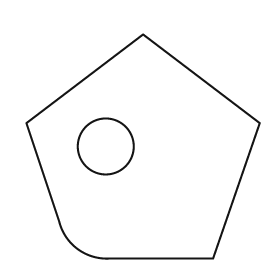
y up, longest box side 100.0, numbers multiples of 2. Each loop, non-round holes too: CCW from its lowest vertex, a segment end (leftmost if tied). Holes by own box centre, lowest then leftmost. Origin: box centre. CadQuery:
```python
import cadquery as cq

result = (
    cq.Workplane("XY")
    .moveTo(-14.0, -48.0)
    .lineTo(30.0, -48.0)
    .lineTo(50.0, 10.0)
    .lineTo(0.0, 48.0)
    .lineTo(-50.0, 10.0)
    .lineTo(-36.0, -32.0)
    .threePointArc((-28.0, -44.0), (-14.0, -48.0))
    .close()
    .moveTo(-16.0, 0.0)
    .circle(12.0)
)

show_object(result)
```